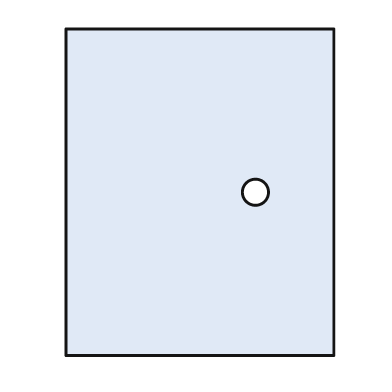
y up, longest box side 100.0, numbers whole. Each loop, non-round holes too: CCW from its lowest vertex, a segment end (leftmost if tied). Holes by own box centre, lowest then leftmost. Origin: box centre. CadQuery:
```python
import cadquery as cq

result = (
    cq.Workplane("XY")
    .moveTo(-41.0, -50.0)
    .lineTo(41.0, -50.0)
    .lineTo(41.0, 50.0)
    .lineTo(-41.0, 50.0)
    .close()
    .moveTo(17.0, 0.0)
    .circle(4.0)
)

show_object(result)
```